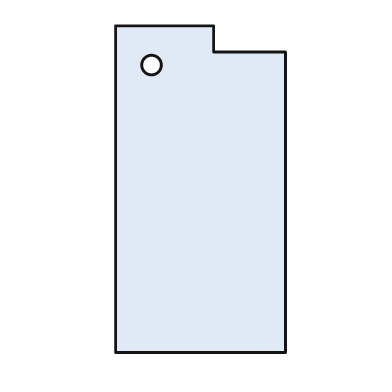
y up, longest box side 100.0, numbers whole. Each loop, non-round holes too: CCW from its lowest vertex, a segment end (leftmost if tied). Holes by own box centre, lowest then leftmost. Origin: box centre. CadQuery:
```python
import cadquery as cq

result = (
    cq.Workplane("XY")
    .moveTo(-26.0, -50.0)
    .lineTo(26.0, -50.0)
    .lineTo(26.0, 42.0)
    .lineTo(4.0, 42.0)
    .lineTo(4.0, 50.0)
    .lineTo(-26.0, 50.0)
    .close()
    .moveTo(-15.0, 38.0)
    .circle(3.0)
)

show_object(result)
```